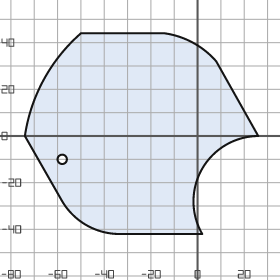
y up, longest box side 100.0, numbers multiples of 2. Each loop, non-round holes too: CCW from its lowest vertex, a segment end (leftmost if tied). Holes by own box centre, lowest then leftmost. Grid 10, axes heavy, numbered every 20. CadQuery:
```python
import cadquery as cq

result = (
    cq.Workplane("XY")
    .moveTo(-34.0, -42.0)
    .lineTo(2.0, -42.0)
    .threePointArc((2.0, -14.0), (26.0, 0.0))
    .lineTo(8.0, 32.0)
    .threePointArc((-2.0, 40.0), (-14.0, 44.0))
    .lineTo(-50.0, 44.0)
    .threePointArc((-66.0, 24.0), (-74.0, 0.0))
    .lineTo(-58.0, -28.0)
    .threePointArc((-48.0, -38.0), (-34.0, -42.0))
    .close()
    .moveTo(-58.0, -10.0)
    .circle(2.0)
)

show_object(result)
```